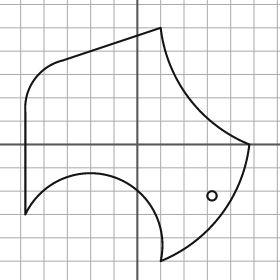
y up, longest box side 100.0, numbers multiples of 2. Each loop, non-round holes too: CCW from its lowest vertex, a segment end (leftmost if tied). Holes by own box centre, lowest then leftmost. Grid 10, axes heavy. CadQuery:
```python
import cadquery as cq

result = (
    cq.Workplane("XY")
    .moveTo(10.0, -50.0)
    .threePointArc((36.0, -30.0), (48.0, 0.0))
    .threePointArc((22.0, 20.0), (10.0, 50.0))
    .lineTo(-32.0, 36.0)
    .threePointArc((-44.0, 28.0), (-48.0, 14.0))
    .lineTo(-48.0, -30.0)
    .threePointArc((-10.0, -14.0), (10.0, -50.0))
    .close()
    .moveTo(32.0, -22.0)
    .circle(2.0)
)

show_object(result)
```